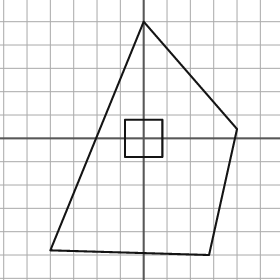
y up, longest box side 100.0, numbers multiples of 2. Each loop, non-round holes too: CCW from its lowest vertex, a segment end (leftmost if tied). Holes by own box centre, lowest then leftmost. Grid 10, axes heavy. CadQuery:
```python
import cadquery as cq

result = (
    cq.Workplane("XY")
    .moveTo(28.0, -50.0)
    .lineTo(40.0, 4.0)
    .lineTo(0.0, 50.0)
    .lineTo(-40.0, -48.0)
    .close()
    .moveTo(-8.0, -8.0)
    .lineTo(8.0, -8.0)
    .lineTo(8.0, 8.0)
    .lineTo(-8.0, 8.0)
    .close()
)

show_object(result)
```